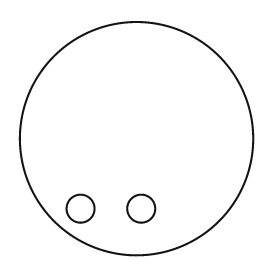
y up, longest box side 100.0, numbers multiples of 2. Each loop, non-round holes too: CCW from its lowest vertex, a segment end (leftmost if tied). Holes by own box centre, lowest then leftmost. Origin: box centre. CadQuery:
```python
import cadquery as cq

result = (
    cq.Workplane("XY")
    .moveTo(0.0, 0.0)
    .circle(50.0)
    .moveTo(-24.0, -30.0)
    .circle(6.0)
    .moveTo(2.0, -30.0)
    .circle(6.0)
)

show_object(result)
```